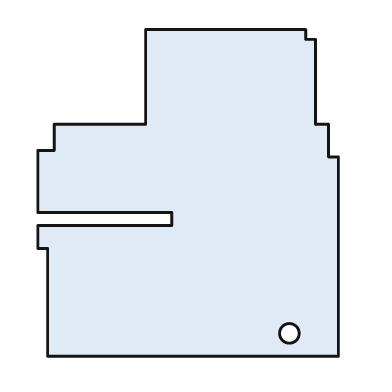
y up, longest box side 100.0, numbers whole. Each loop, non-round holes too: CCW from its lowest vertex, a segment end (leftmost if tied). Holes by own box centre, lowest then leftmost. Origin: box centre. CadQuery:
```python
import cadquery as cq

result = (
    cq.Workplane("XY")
    .moveTo(-43.0, -50.0)
    .lineTo(46.0, -50.0)
    .lineTo(46.0, 11.0)
    .lineTo(43.0, 11.0)
    .lineTo(43.0, 21.0)
    .lineTo(39.0, 21.0)
    .lineTo(39.0, 47.0)
    .lineTo(36.0, 47.0)
    .lineTo(36.0, 50.0)
    .lineTo(-13.0, 50.0)
    .lineTo(-13.0, 21.0)
    .lineTo(-41.0, 21.0)
    .lineTo(-41.0, 13.0)
    .lineTo(-46.0, 13.0)
    .lineTo(-46.0, -6.0)
    .lineTo(-5.0, -6.0)
    .lineTo(-5.0, -10.0)
    .lineTo(-46.0, -10.0)
    .lineTo(-46.0, -17.0)
    .lineTo(-43.0, -17.0)
    .close()
    .moveTo(31.0, -43.0)
    .circle(3.0)
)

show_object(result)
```